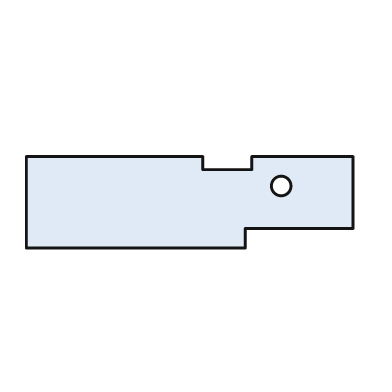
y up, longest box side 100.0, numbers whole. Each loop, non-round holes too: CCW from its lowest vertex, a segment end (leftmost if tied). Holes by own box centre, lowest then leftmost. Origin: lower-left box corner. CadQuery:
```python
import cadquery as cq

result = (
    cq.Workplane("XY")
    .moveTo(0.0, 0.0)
    .lineTo(67.0, 0.0)
    .lineTo(67.0, 6.0)
    .lineTo(100.0, 6.0)
    .lineTo(100.0, 28.0)
    .lineTo(69.0, 28.0)
    .lineTo(69.0, 24.0)
    .lineTo(54.0, 24.0)
    .lineTo(54.0, 28.0)
    .lineTo(0.0, 28.0)
    .close()
    .moveTo(78.0, 19.0)
    .circle(3.0)
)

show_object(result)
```